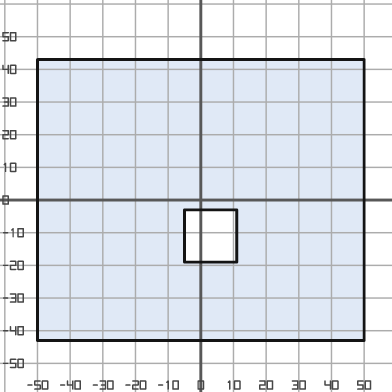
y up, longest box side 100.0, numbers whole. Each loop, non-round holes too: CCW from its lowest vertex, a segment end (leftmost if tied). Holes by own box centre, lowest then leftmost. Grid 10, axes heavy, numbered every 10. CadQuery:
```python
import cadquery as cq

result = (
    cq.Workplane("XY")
    .moveTo(-50.0, -43.0)
    .lineTo(50.0, -43.0)
    .lineTo(50.0, 43.0)
    .lineTo(-50.0, 43.0)
    .close()
    .moveTo(-5.0, -19.0)
    .lineTo(11.0, -19.0)
    .lineTo(11.0, -3.0)
    .lineTo(-5.0, -3.0)
    .close()
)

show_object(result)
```